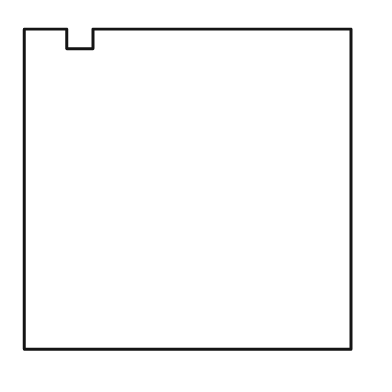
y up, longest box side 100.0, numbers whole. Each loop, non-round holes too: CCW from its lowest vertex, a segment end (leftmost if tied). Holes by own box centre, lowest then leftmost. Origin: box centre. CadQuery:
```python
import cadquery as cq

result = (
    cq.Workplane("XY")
    .moveTo(-50.0, -49.0)
    .lineTo(50.0, -49.0)
    .lineTo(50.0, 49.0)
    .lineTo(-29.0, 49.0)
    .lineTo(-29.0, 43.0)
    .lineTo(-37.0, 43.0)
    .lineTo(-37.0, 49.0)
    .lineTo(-50.0, 49.0)
    .close()
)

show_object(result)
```